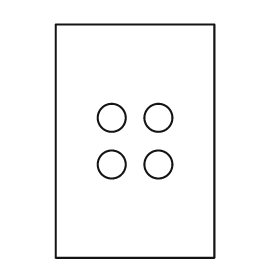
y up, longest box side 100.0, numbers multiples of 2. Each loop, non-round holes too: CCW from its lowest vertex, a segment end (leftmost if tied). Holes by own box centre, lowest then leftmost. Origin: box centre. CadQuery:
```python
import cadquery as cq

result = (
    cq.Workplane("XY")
    .moveTo(-34.0, -50.0)
    .lineTo(34.0, -50.0)
    .lineTo(34.0, 50.0)
    .lineTo(-34.0, 50.0)
    .close()
    .moveTo(-10.0, -10.0)
    .circle(6.0)
    .moveTo(10.0, -10.0)
    .circle(6.0)
    .moveTo(-10.0, 10.0)
    .circle(6.0)
    .moveTo(10.0, 10.0)
    .circle(6.0)
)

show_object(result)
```